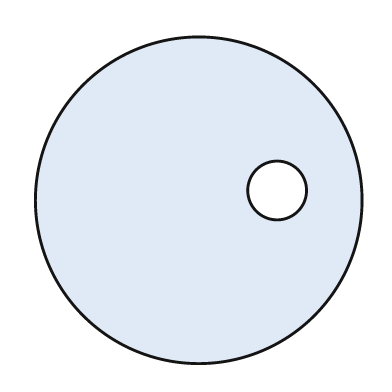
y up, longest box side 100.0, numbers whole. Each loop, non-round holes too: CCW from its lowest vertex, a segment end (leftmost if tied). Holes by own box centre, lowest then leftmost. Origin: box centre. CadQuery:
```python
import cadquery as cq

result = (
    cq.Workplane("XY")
    .moveTo(0.0, 0.0)
    .circle(50.0)
    .moveTo(24.0, 3.0)
    .circle(9.0)
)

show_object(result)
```